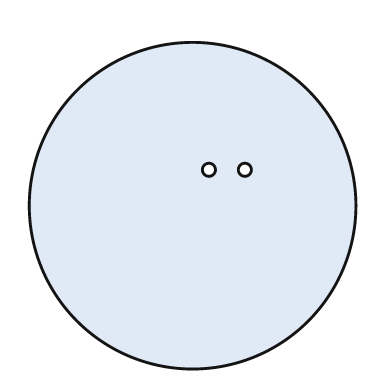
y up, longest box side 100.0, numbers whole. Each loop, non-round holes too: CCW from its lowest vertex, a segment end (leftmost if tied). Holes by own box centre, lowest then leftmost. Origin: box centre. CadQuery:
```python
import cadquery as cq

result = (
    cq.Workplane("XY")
    .moveTo(0.0, 0.0)
    .circle(50.0)
    .moveTo(5.0, 11.0)
    .circle(2.0)
    .moveTo(16.0, 11.0)
    .circle(2.0)
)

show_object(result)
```